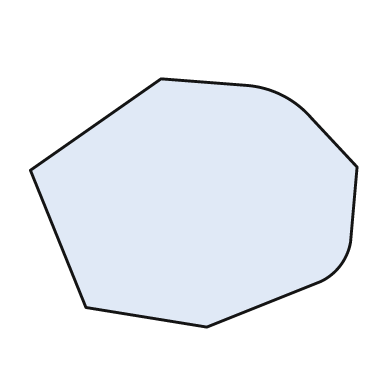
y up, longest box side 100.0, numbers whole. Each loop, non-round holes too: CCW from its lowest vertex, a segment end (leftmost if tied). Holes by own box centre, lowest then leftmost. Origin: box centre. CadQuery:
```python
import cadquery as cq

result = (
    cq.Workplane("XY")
    .moveTo(4.0, -38.0)
    .lineTo(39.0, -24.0)
    .threePointArc((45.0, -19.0), (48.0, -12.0))
    .lineTo(50.0, 11.0)
    .lineTo(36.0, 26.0)
    .threePointArc((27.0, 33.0), (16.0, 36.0))
    .lineTo(-10.0, 38.0)
    .lineTo(-50.0, 10.0)
    .lineTo(-33.0, -32.0)
    .close()
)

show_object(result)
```